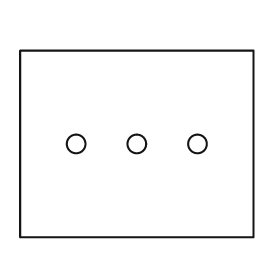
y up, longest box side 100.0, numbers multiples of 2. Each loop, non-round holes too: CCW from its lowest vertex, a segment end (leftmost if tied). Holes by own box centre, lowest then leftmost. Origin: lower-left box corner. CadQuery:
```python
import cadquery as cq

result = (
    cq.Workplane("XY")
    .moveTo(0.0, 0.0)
    .lineTo(100.0, 0.0)
    .lineTo(100.0, 80.0)
    .lineTo(0.0, 80.0)
    .close()
    .moveTo(24.0, 40.0)
    .circle(4.0)
    .moveTo(50.0, 40.0)
    .circle(4.0)
    .moveTo(76.0, 40.0)
    .circle(4.0)
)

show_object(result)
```